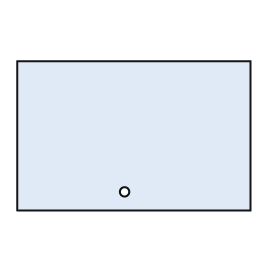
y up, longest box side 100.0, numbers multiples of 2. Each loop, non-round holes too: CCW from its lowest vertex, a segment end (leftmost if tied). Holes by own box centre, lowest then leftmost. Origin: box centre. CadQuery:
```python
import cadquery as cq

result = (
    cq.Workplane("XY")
    .moveTo(-50.0, -32.0)
    .lineTo(50.0, -32.0)
    .lineTo(50.0, 32.0)
    .lineTo(-50.0, 32.0)
    .close()
    .moveTo(-4.0, -24.0)
    .circle(2.0)
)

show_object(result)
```